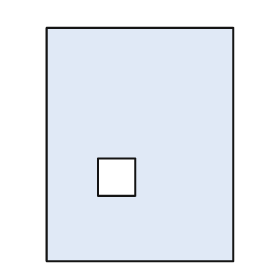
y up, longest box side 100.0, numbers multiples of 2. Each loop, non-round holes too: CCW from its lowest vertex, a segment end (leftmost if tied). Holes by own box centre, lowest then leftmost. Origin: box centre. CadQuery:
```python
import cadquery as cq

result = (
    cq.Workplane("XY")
    .moveTo(-40.0, -50.0)
    .lineTo(40.0, -50.0)
    .lineTo(40.0, 50.0)
    .lineTo(-40.0, 50.0)
    .close()
    .moveTo(-18.0, -22.0)
    .lineTo(-2.0, -22.0)
    .lineTo(-2.0, -6.0)
    .lineTo(-18.0, -6.0)
    .close()
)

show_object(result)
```